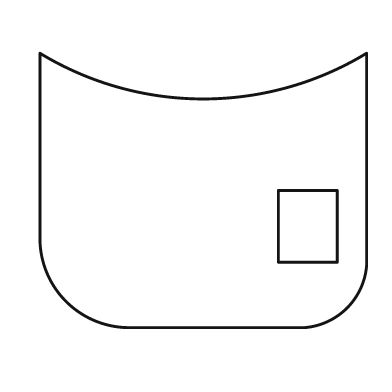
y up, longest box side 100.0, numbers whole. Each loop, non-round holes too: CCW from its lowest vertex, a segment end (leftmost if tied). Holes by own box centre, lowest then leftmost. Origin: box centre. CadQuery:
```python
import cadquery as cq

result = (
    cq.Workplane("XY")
    .moveTo(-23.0, -42.0)
    .lineTo(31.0, -42.0)
    .threePointArc((44.0, -36.0), (50.0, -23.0))
    .lineTo(50.0, 42.0)
    .threePointArc((0.0, 28.0), (-50.0, 42.0))
    .lineTo(-50.0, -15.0)
    .threePointArc((-42.0, -34.0), (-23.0, -42.0))
    .close()
    .moveTo(23.0, -22.0)
    .lineTo(41.0, -22.0)
    .lineTo(41.0, 0.0)
    .lineTo(23.0, 0.0)
    .close()
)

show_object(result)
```